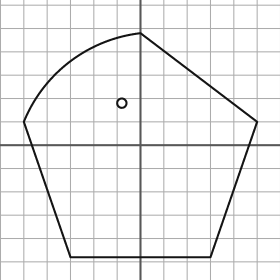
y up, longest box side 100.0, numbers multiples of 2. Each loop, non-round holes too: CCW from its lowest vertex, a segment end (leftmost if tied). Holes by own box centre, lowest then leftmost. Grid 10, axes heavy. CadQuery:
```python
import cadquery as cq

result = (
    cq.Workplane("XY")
    .moveTo(-30.0, -48.0)
    .lineTo(30.0, -48.0)
    .lineTo(50.0, 10.0)
    .lineTo(0.0, 48.0)
    .threePointArc((-30.0, 36.0), (-50.0, 10.0))
    .close()
    .moveTo(-8.0, 18.0)
    .circle(2.0)
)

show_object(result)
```